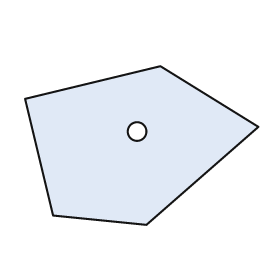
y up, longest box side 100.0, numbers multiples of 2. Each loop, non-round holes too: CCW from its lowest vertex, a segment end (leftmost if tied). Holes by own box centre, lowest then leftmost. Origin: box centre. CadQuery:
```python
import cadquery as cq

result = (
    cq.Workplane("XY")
    .moveTo(2.0, -34.0)
    .lineTo(50.0, 8.0)
    .lineTo(8.0, 34.0)
    .lineTo(-50.0, 20.0)
    .lineTo(-38.0, -30.0)
    .close()
    .moveTo(-2.0, 6.0)
    .circle(4.0)
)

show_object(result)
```